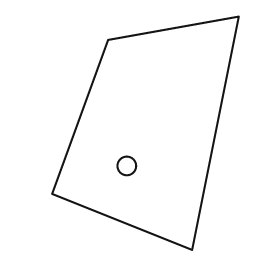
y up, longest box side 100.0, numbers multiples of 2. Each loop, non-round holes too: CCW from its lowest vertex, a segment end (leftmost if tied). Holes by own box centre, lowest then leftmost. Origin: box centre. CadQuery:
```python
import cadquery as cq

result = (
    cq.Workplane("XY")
    .moveTo(20.0, -50.0)
    .lineTo(40.0, 50.0)
    .lineTo(-16.0, 40.0)
    .lineTo(-40.0, -26.0)
    .close()
    .moveTo(-8.0, -14.0)
    .circle(4.0)
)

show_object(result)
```